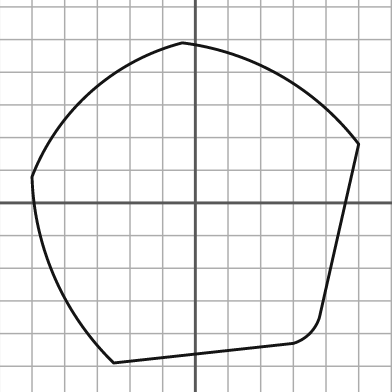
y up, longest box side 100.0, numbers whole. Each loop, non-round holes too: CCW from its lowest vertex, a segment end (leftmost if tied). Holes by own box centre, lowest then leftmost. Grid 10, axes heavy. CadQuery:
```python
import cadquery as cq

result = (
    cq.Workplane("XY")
    .moveTo(-25.0, -49.0)
    .lineTo(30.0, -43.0)
    .threePointArc((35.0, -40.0), (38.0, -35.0))
    .lineTo(50.0, 18.0)
    .threePointArc((26.0, 39.0), (-4.0, 49.0))
    .threePointArc((-32.0, 34.0), (-50.0, 8.0))
    .threePointArc((-43.0, -23.0), (-25.0, -49.0))
    .close()
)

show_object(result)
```